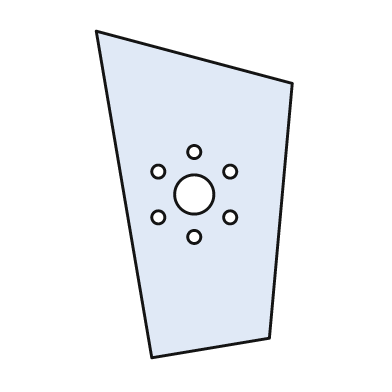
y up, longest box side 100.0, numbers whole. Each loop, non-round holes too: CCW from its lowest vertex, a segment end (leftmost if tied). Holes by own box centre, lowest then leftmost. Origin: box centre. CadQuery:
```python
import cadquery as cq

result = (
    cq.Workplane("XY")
    .moveTo(-13.0, -50.0)
    .lineTo(23.0, -44.0)
    .lineTo(30.0, 34.0)
    .lineTo(-30.0, 50.0)
    .close()
    .moveTo(0.0, -13.0)
    .circle(2.0)
    .moveTo(-11.0, -7.0)
    .circle(2.0)
    .moveTo(11.0, -7.0)
    .circle(2.0)
    .moveTo(0.0, 0.0)
    .circle(6.0)
    .moveTo(-11.0, 7.0)
    .circle(2.0)
    .moveTo(11.0, 7.0)
    .circle(2.0)
    .moveTo(0.0, 13.0)
    .circle(2.0)
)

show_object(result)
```